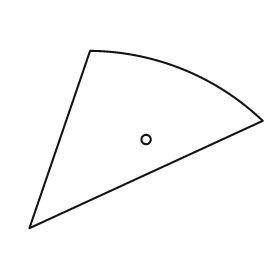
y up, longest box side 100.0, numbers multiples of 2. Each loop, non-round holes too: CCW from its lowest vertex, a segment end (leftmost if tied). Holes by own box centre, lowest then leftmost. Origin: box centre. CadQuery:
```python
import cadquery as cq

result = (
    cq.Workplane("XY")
    .moveTo(-50.0, -38.0)
    .lineTo(50.0, 8.0)
    .threePointArc((16.0, 30.0), (-24.0, 38.0))
    .close()
    .moveTo(0.0, 0.0)
    .circle(2.0)
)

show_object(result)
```